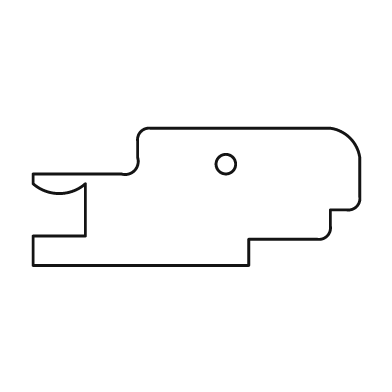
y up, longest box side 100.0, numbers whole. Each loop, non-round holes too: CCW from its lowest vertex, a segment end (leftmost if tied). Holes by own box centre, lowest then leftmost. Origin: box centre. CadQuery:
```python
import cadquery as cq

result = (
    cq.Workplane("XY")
    .moveTo(-50.0, -21.0)
    .lineTo(16.0, -21.0)
    .lineTo(16.0, -13.0)
    .lineTo(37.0, -13.0)
    .threePointArc((40.0, -12.0), (41.0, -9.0))
    .lineTo(41.0, -4.0)
    .lineTo(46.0, -4.0)
    .threePointArc((49.0, -3.0), (50.0, 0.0))
    .lineTo(50.0, 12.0)
    .threePointArc((47.0, 18.0), (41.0, 21.0))
    .lineTo(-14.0, 21.0)
    .threePointArc((-17.0, 20.0), (-18.0, 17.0))
    .lineTo(-18.0, 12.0)
    .threePointArc((-19.0, 8.0), (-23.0, 7.0))
    .lineTo(-50.0, 7.0)
    .lineTo(-50.0, 4.0)
    .threePointArc((-42.0, 1.0), (-34.0, 4.0))
    .lineTo(-34.0, -12.0)
    .lineTo(-50.0, -12.0)
    .close()
    .moveTo(9.0, 10.0)
    .circle(3.0)
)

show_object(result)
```